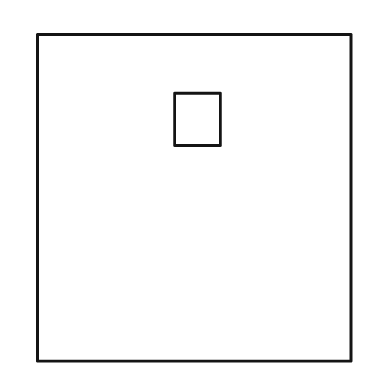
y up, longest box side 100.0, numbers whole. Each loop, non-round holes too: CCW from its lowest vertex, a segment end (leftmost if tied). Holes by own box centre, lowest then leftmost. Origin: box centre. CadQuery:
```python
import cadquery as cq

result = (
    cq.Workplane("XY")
    .moveTo(-48.0, -50.0)
    .lineTo(48.0, -50.0)
    .lineTo(48.0, 50.0)
    .lineTo(-48.0, 50.0)
    .close()
    .moveTo(-6.0, 16.0)
    .lineTo(8.0, 16.0)
    .lineTo(8.0, 32.0)
    .lineTo(-6.0, 32.0)
    .close()
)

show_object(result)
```